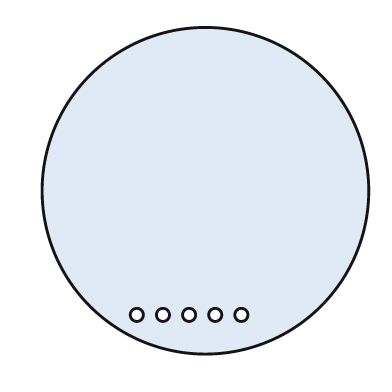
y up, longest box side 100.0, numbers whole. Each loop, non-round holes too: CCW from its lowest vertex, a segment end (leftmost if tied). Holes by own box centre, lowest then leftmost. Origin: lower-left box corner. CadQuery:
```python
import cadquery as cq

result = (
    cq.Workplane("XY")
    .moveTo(50.0, 50.0)
    .circle(50.0)
    .moveTo(29.0, 12.0)
    .circle(2.0)
    .moveTo(37.0, 12.0)
    .circle(2.0)
    .moveTo(45.0, 12.0)
    .circle(2.0)
    .moveTo(53.0, 12.0)
    .circle(2.0)
    .moveTo(61.0, 12.0)
    .circle(2.0)
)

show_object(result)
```